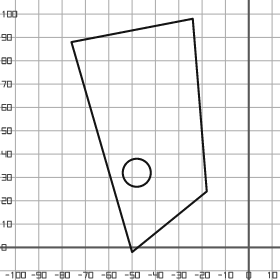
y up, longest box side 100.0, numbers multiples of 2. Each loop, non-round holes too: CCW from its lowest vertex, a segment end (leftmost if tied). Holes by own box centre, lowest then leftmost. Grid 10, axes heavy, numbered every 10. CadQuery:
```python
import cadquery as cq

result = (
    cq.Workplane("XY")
    .moveTo(-50.0, -2.0)
    .lineTo(-18.0, 24.0)
    .lineTo(-24.0, 98.0)
    .lineTo(-76.0, 88.0)
    .close()
    .moveTo(-48.0, 32.0)
    .circle(6.0)
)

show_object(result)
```